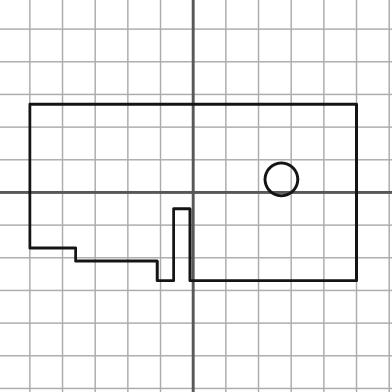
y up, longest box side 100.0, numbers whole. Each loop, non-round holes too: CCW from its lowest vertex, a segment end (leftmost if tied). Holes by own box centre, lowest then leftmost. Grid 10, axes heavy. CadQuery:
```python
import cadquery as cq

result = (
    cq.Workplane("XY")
    .moveTo(-11.0, -27.0)
    .lineTo(-6.0, -27.0)
    .lineTo(-6.0, -5.0)
    .lineTo(-1.0, -5.0)
    .lineTo(-1.0, -27.0)
    .lineTo(50.0, -27.0)
    .lineTo(50.0, 27.0)
    .lineTo(-50.0, 27.0)
    .lineTo(-50.0, -17.0)
    .lineTo(-36.0, -17.0)
    .lineTo(-36.0, -21.0)
    .lineTo(-11.0, -21.0)
    .close()
    .moveTo(27.0, 4.0)
    .circle(5.0)
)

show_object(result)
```